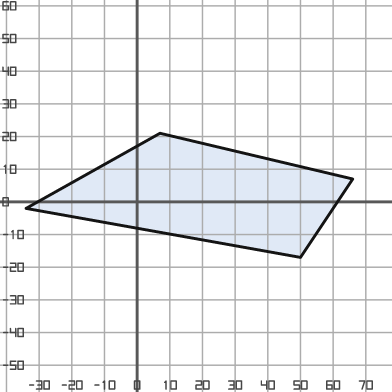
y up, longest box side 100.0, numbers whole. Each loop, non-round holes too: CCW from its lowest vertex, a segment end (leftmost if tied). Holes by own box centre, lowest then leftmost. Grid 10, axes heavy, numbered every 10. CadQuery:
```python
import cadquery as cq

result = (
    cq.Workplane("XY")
    .moveTo(50.0, -17.0)
    .lineTo(66.0, 7.0)
    .lineTo(7.0, 21.0)
    .lineTo(-34.0, -2.0)
    .close()
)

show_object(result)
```